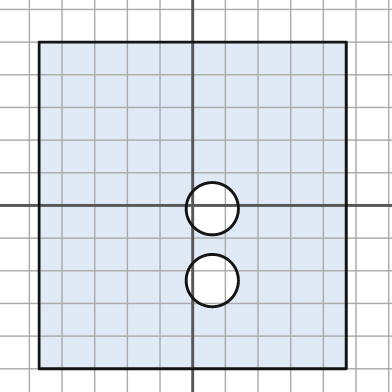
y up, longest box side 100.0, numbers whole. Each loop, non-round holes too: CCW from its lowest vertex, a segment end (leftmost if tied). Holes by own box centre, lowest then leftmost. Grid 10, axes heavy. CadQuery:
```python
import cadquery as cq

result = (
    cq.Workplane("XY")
    .moveTo(-47.0, -50.0)
    .lineTo(47.0, -50.0)
    .lineTo(47.0, 50.0)
    .lineTo(-47.0, 50.0)
    .close()
    .moveTo(6.0, -23.0)
    .circle(8.0)
    .moveTo(6.0, -1.0)
    .circle(8.0)
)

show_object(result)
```